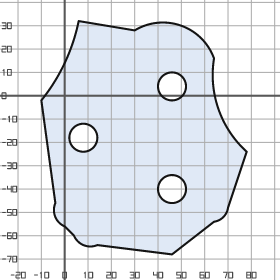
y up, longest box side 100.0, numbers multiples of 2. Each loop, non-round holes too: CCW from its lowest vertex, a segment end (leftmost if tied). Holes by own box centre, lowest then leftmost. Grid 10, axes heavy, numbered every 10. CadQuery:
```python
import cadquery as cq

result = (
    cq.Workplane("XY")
    .moveTo(46.0, -68.0)
    .lineTo(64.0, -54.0)
    .threePointArc((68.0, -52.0), (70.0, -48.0))
    .lineTo(78.0, -24.0)
    .threePointArc((66.0, -6.0), (64.0, 16.0))
    .threePointArc((50.0, 30.0), (30.0, 28.0))
    .lineTo(6.0, 32.0)
    .threePointArc((0.0, 14.0), (-10.0, -2.0))
    .lineTo(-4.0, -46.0)
    .threePointArc((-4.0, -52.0), (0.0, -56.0))
    .lineTo(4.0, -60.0)
    .threePointArc((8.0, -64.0), (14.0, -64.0))
    .close()
    .moveTo(46.0, -40.0)
    .circle(6.0)
    .moveTo(8.0, -18.0)
    .circle(6.0)
    .moveTo(46.0, 4.0)
    .circle(6.0)
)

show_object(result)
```